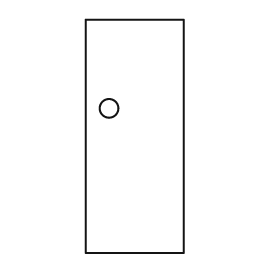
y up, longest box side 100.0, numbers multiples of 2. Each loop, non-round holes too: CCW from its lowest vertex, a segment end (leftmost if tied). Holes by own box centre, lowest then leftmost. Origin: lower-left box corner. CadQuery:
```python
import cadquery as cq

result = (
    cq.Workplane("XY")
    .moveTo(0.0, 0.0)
    .lineTo(42.0, 0.0)
    .lineTo(42.0, 100.0)
    .lineTo(0.0, 100.0)
    .close()
    .moveTo(10.0, 62.0)
    .circle(4.0)
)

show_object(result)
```